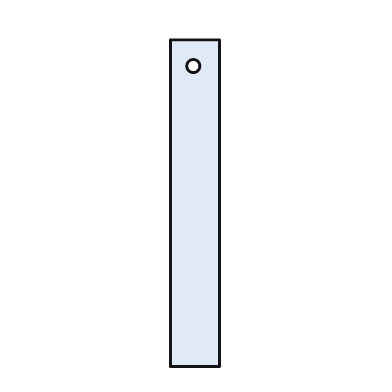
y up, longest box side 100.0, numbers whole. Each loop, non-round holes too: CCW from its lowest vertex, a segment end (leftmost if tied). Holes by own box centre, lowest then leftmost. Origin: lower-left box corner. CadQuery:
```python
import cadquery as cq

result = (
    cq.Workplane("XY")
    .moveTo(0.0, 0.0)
    .lineTo(15.0, 0.0)
    .lineTo(15.0, 100.0)
    .lineTo(0.0, 100.0)
    .close()
    .moveTo(7.0, 92.0)
    .circle(2.0)
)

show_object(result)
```